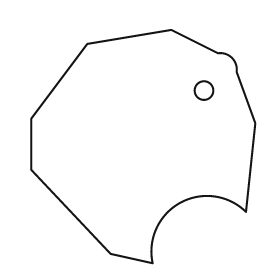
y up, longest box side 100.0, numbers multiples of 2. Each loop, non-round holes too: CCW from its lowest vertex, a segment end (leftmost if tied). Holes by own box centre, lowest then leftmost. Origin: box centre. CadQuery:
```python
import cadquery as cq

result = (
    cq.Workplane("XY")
    .moveTo(4.0, -50.0)
    .threePointArc((16.0, -24.0), (44.0, -28.0))
    .lineTo(48.0, 10.0)
    .lineTo(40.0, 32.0)
    .threePointArc((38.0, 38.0), (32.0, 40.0))
    .lineTo(12.0, 50.0)
    .lineTo(-24.0, 44.0)
    .lineTo(-48.0, 12.0)
    .lineTo(-48.0, -10.0)
    .lineTo(-14.0, -46.0)
    .close()
    .moveTo(26.0, 24.0)
    .circle(4.0)
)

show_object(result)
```